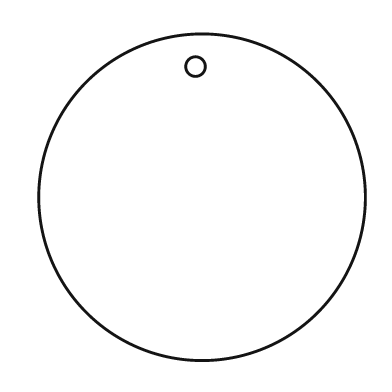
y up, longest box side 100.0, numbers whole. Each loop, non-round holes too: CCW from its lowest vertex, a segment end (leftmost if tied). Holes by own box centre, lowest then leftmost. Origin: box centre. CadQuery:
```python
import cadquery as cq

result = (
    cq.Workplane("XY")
    .moveTo(0.0, 0.0)
    .circle(50.0)
    .moveTo(-2.0, 40.0)
    .circle(3.0)
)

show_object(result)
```